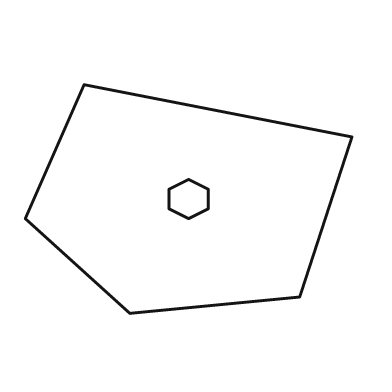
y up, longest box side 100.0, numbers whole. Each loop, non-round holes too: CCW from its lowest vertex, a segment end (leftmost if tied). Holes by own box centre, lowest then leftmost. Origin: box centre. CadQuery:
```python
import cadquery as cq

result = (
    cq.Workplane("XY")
    .moveTo(-18.0, -35.0)
    .lineTo(34.0, -30.0)
    .lineTo(50.0, 19.0)
    .lineTo(-32.0, 35.0)
    .lineTo(-50.0, -6.0)
    .close()
    .moveTo(0.0, -6.0)
    .lineTo(6.0, -3.0)
    .lineTo(6.0, 3.0)
    .lineTo(0.0, 6.0)
    .lineTo(-6.0, 3.0)
    .lineTo(-6.0, -3.0)
    .close()
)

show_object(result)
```